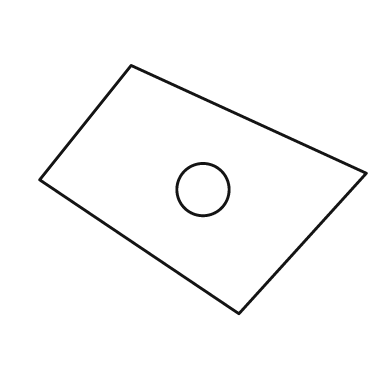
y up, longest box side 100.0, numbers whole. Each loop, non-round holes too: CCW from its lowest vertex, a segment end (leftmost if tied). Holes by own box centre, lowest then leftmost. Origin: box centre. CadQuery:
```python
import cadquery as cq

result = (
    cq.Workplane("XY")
    .moveTo(11.0, -38.0)
    .lineTo(50.0, 5.0)
    .lineTo(-22.0, 38.0)
    .lineTo(-50.0, 3.0)
    .close()
    .moveTo(0.0, 0.0)
    .circle(8.0)
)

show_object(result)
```